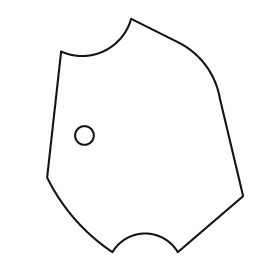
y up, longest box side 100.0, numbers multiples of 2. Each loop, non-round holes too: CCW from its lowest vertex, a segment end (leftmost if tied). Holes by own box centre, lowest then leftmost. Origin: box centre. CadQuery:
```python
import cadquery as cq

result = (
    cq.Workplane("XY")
    .moveTo(-14.0, -50.0)
    .threePointArc((0.0, -42.0), (14.0, -50.0))
    .lineTo(42.0, -26.0)
    .lineTo(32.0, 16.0)
    .threePointArc((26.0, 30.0), (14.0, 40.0))
    .lineTo(-6.0, 50.0)
    .threePointArc((-18.0, 36.0), (-36.0, 36.0))
    .lineTo(-42.0, -18.0)
    .threePointArc((-30.0, -36.0), (-14.0, -50.0))
    .close()
    .moveTo(-26.0, 0.0)
    .circle(4.0)
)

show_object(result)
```